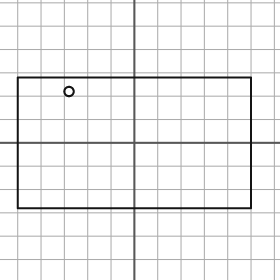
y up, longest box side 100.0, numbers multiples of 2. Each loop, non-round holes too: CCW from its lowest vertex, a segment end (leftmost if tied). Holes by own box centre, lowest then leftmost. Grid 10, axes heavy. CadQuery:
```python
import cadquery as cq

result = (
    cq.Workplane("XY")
    .moveTo(-50.0, -28.0)
    .lineTo(50.0, -28.0)
    .lineTo(50.0, 28.0)
    .lineTo(-50.0, 28.0)
    .close()
    .moveTo(-28.0, 22.0)
    .circle(2.0)
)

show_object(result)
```